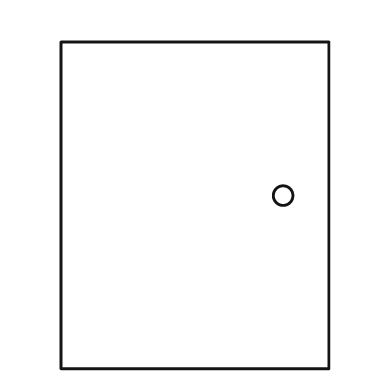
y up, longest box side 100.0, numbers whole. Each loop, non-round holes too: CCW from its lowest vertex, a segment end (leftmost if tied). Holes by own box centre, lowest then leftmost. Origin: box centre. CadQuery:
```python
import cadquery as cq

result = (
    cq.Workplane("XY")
    .moveTo(-41.0, -50.0)
    .lineTo(41.0, -50.0)
    .lineTo(41.0, 50.0)
    .lineTo(-41.0, 50.0)
    .close()
    .moveTo(27.0, 3.0)
    .circle(3.0)
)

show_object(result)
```